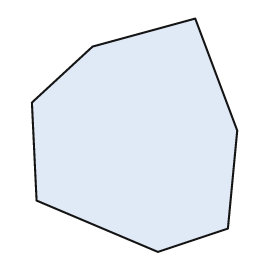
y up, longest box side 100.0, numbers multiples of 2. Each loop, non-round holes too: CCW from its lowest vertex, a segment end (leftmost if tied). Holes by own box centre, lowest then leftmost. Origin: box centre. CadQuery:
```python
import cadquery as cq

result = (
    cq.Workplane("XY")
    .moveTo(10.0, -50.0)
    .lineTo(40.0, -40.0)
    .lineTo(44.0, 2.0)
    .lineTo(26.0, 50.0)
    .lineTo(-18.0, 38.0)
    .lineTo(-44.0, 14.0)
    .lineTo(-42.0, -28.0)
    .close()
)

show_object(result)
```